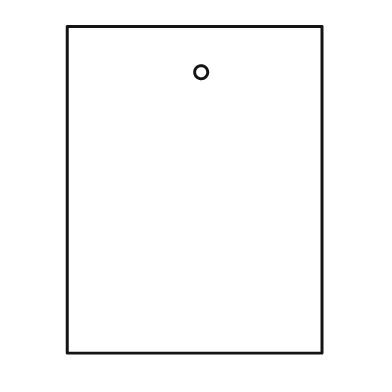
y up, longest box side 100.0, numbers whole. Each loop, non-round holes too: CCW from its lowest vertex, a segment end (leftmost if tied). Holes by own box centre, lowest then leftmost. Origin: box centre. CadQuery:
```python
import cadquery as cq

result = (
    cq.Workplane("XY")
    .moveTo(-39.0, -50.0)
    .lineTo(39.0, -50.0)
    .lineTo(39.0, 50.0)
    .lineTo(-39.0, 50.0)
    .close()
    .moveTo(2.0, 36.0)
    .circle(2.0)
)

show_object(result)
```